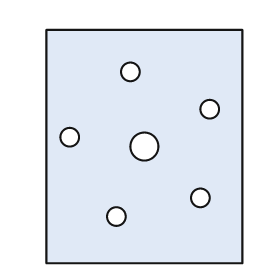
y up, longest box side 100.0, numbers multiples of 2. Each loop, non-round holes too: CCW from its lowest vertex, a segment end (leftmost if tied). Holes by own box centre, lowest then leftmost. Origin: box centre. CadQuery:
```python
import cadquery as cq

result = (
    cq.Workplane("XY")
    .moveTo(-42.0, -50.0)
    .lineTo(42.0, -50.0)
    .lineTo(42.0, 50.0)
    .lineTo(-42.0, 50.0)
    .close()
    .moveTo(-12.0, -30.0)
    .circle(4.0)
    .moveTo(24.0, -22.0)
    .circle(4.0)
    .moveTo(0.0, 0.0)
    .circle(6.0)
    .moveTo(-32.0, 4.0)
    .circle(4.0)
    .moveTo(28.0, 16.0)
    .circle(4.0)
    .moveTo(-6.0, 32.0)
    .circle(4.0)
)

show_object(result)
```